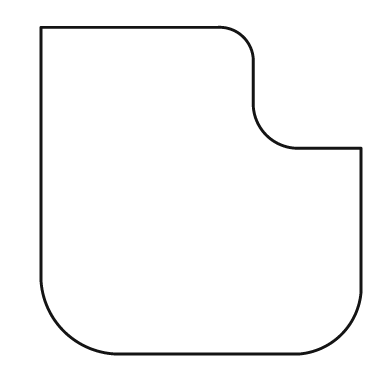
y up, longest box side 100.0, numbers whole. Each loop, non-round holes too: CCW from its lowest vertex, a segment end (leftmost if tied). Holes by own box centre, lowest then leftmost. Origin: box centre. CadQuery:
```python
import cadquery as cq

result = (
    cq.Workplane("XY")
    .moveTo(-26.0, -50.0)
    .lineTo(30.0, -50.0)
    .threePointArc((43.0, -44.0), (49.0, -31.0))
    .lineTo(49.0, 13.0)
    .lineTo(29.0, 13.0)
    .threePointArc((20.0, 17.0), (16.0, 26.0))
    .lineTo(16.0, 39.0)
    .threePointArc((13.0, 47.0), (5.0, 50.0))
    .lineTo(-49.0, 50.0)
    .lineTo(-49.0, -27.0)
    .threePointArc((-42.0, -43.0), (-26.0, -50.0))
    .close()
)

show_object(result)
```